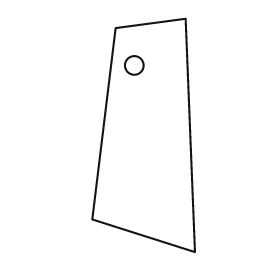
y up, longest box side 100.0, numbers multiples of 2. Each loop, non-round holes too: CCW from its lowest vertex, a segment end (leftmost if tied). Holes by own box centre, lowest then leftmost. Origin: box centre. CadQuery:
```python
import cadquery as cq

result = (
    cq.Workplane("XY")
    .moveTo(22.0, -50.0)
    .lineTo(18.0, 50.0)
    .lineTo(-12.0, 46.0)
    .lineTo(-22.0, -36.0)
    .close()
    .moveTo(-4.0, 30.0)
    .circle(4.0)
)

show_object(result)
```